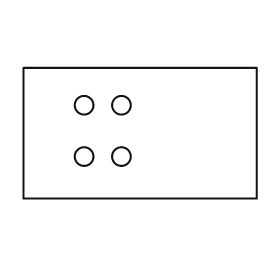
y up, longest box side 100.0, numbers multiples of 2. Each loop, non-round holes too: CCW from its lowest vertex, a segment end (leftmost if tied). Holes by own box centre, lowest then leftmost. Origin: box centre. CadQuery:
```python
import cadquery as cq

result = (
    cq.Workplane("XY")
    .moveTo(-50.0, -28.0)
    .lineTo(50.0, -28.0)
    .lineTo(50.0, 28.0)
    .lineTo(-50.0, 28.0)
    .close()
    .moveTo(-24.0, -10.0)
    .circle(4.0)
    .moveTo(-8.0, -10.0)
    .circle(4.0)
    .moveTo(-24.0, 12.0)
    .circle(4.0)
    .moveTo(-8.0, 12.0)
    .circle(4.0)
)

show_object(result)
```